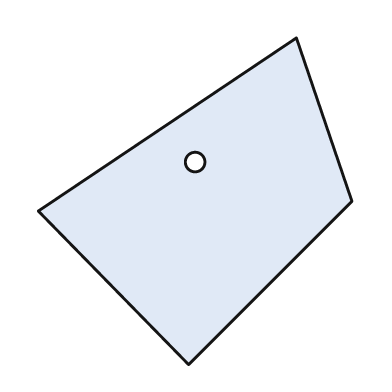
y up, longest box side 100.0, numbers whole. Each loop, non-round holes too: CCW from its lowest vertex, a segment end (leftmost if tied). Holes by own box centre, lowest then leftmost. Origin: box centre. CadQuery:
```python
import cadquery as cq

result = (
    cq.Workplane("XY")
    .moveTo(-2.0, -50.0)
    .lineTo(48.0, 0.0)
    .lineTo(31.0, 50.0)
    .lineTo(-48.0, -3.0)
    .close()
    .moveTo(0.0, 12.0)
    .circle(3.0)
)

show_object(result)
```